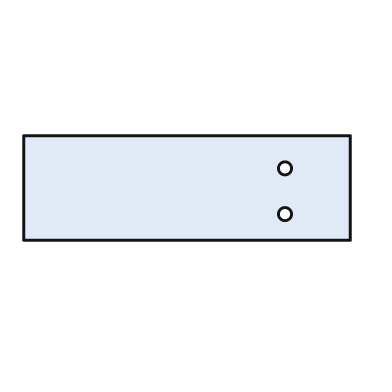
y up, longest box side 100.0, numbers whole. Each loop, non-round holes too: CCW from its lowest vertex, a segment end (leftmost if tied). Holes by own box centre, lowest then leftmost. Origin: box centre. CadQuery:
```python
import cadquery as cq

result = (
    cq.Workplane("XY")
    .moveTo(-50.0, -16.0)
    .lineTo(50.0, -16.0)
    .lineTo(50.0, 16.0)
    .lineTo(-50.0, 16.0)
    .close()
    .moveTo(30.0, -8.0)
    .circle(2.0)
    .moveTo(30.0, 6.0)
    .circle(2.0)
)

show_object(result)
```